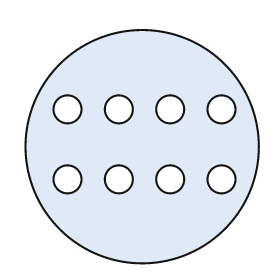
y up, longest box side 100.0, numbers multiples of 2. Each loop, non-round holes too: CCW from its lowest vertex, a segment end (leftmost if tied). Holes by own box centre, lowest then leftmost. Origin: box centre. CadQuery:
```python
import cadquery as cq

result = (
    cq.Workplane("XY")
    .moveTo(0.0, 0.0)
    .circle(50.0)
    .moveTo(-32.0, -14.0)
    .circle(6.0)
    .moveTo(-10.0, -14.0)
    .circle(6.0)
    .moveTo(12.0, -14.0)
    .circle(6.0)
    .moveTo(34.0, -14.0)
    .circle(6.0)
    .moveTo(-32.0, 16.0)
    .circle(6.0)
    .moveTo(-10.0, 16.0)
    .circle(6.0)
    .moveTo(12.0, 16.0)
    .circle(6.0)
    .moveTo(34.0, 16.0)
    .circle(6.0)
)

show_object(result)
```